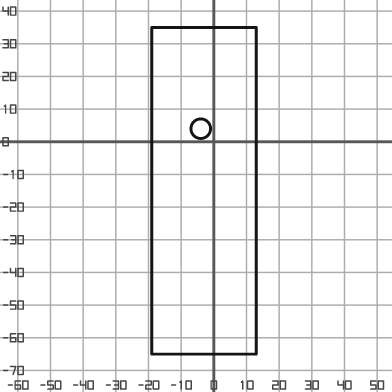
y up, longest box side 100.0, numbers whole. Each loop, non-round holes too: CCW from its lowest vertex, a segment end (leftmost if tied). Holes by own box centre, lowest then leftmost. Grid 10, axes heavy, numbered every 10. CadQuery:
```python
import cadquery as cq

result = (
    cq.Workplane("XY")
    .moveTo(-19.0, -65.0)
    .lineTo(13.0, -65.0)
    .lineTo(13.0, 35.0)
    .lineTo(-19.0, 35.0)
    .close()
    .moveTo(-4.0, 4.0)
    .circle(3.0)
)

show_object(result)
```